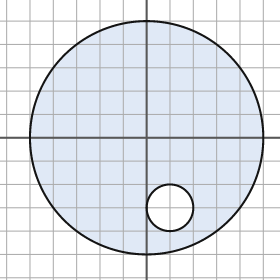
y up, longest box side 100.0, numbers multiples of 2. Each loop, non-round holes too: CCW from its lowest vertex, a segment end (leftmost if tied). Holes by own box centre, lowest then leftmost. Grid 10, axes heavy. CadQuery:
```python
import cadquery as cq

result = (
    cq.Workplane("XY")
    .moveTo(0.0, 0.0)
    .circle(50.0)
    .moveTo(10.0, -30.0)
    .circle(10.0)
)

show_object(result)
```